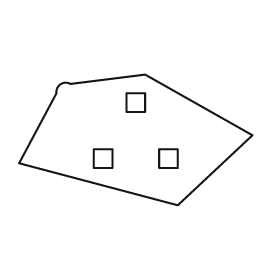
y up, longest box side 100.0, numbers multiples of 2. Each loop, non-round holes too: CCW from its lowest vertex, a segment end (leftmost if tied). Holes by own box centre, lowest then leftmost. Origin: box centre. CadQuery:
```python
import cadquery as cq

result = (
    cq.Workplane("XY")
    .moveTo(18.0, -28.0)
    .lineTo(50.0, 2.0)
    .lineTo(4.0, 28.0)
    .lineTo(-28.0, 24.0)
    .threePointArc((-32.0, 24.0), (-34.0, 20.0))
    .lineTo(-50.0, -10.0)
    .close()
    .moveTo(-18.0, -12.0)
    .lineTo(-10.0, -12.0)
    .lineTo(-10.0, -4.0)
    .lineTo(-18.0, -4.0)
    .close()
    .moveTo(10.0, -12.0)
    .lineTo(18.0, -12.0)
    .lineTo(18.0, -4.0)
    .lineTo(10.0, -4.0)
    .close()
    .moveTo(-4.0, 12.0)
    .lineTo(4.0, 12.0)
    .lineTo(4.0, 20.0)
    .lineTo(-4.0, 20.0)
    .close()
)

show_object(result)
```